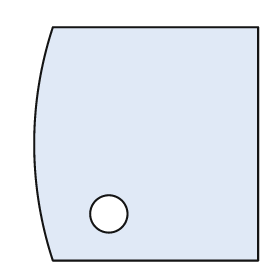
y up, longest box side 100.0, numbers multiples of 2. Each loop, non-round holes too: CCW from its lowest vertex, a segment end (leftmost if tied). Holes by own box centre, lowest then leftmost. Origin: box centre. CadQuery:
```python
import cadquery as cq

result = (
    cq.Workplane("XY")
    .moveTo(-40.0, -50.0)
    .lineTo(48.0, -50.0)
    .lineTo(48.0, 50.0)
    .lineTo(-40.0, 50.0)
    .threePointArc((-48.0, 0.0), (-40.0, -50.0))
    .close()
    .moveTo(-16.0, -30.0)
    .circle(8.0)
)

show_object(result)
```